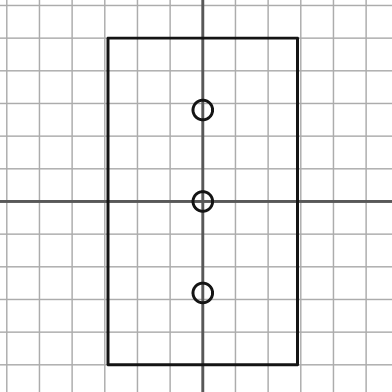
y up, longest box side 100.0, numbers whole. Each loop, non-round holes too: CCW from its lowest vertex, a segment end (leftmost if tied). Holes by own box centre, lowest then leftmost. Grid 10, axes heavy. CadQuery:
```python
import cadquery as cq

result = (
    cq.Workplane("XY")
    .moveTo(-29.0, -50.0)
    .lineTo(29.0, -50.0)
    .lineTo(29.0, 50.0)
    .lineTo(-29.0, 50.0)
    .close()
    .moveTo(0.0, -28.0)
    .circle(3.0)
    .moveTo(0.0, 0.0)
    .circle(3.0)
    .moveTo(0.0, 28.0)
    .circle(3.0)
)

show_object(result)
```